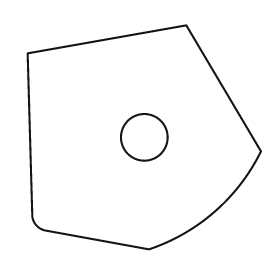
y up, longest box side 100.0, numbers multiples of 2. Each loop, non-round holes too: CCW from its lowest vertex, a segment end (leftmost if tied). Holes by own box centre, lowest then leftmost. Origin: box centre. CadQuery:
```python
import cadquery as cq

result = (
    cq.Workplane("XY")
    .moveTo(2.0, -48.0)
    .threePointArc((30.0, -32.0), (50.0, -6.0))
    .lineTo(18.0, 48.0)
    .lineTo(-50.0, 36.0)
    .lineTo(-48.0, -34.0)
    .threePointArc((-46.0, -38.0), (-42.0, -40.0))
    .close()
    .moveTo(0.0, 0.0)
    .circle(10.0)
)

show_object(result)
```